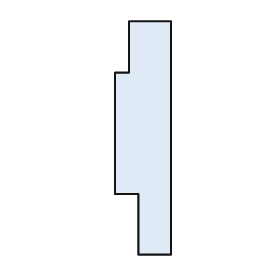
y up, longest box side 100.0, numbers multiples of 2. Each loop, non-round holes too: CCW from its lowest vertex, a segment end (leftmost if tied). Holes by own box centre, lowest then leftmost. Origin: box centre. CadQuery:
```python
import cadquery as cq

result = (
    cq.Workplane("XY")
    .moveTo(-2.0, -50.0)
    .lineTo(12.0, -50.0)
    .lineTo(12.0, 50.0)
    .lineTo(-6.0, 50.0)
    .lineTo(-6.0, 28.0)
    .lineTo(-12.0, 28.0)
    .lineTo(-12.0, -24.0)
    .lineTo(-2.0, -24.0)
    .close()
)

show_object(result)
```